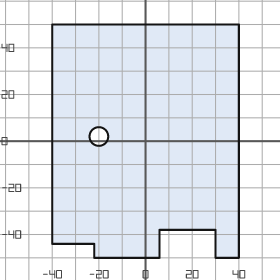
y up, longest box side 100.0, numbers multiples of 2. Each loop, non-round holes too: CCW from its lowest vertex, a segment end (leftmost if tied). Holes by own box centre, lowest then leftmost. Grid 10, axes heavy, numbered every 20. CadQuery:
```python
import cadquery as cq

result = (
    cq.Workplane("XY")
    .moveTo(-22.0, -50.0)
    .lineTo(6.0, -50.0)
    .lineTo(6.0, -38.0)
    .lineTo(30.0, -38.0)
    .lineTo(30.0, -50.0)
    .lineTo(40.0, -50.0)
    .lineTo(40.0, 50.0)
    .lineTo(-40.0, 50.0)
    .lineTo(-40.0, -44.0)
    .lineTo(-22.0, -44.0)
    .close()
    .moveTo(-20.0, 2.0)
    .circle(4.0)
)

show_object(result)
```